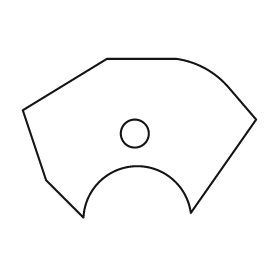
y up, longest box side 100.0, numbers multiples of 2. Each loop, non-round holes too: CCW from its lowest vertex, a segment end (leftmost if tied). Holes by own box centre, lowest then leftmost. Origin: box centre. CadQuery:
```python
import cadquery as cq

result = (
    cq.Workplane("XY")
    .moveTo(-24.0, -34.0)
    .threePointArc((-2.0, -12.0), (22.0, -32.0))
    .lineTo(50.0, 8.0)
    .lineTo(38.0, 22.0)
    .threePointArc((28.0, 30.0), (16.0, 34.0))
    .lineTo(-14.0, 34.0)
    .lineTo(-50.0, 12.0)
    .lineTo(-40.0, -18.0)
    .close()
    .moveTo(-2.0, 2.0)
    .circle(6.0)
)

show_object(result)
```